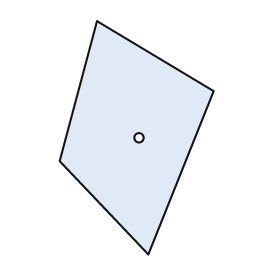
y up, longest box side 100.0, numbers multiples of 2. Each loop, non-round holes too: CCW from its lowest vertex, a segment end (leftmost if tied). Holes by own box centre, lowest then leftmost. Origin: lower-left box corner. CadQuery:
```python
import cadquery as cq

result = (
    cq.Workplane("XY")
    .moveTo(38.0, 0.0)
    .lineTo(66.0, 70.0)
    .lineTo(16.0, 100.0)
    .lineTo(0.0, 40.0)
    .close()
    .moveTo(34.0, 50.0)
    .circle(2.0)
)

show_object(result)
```